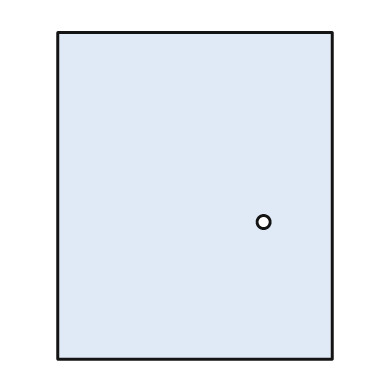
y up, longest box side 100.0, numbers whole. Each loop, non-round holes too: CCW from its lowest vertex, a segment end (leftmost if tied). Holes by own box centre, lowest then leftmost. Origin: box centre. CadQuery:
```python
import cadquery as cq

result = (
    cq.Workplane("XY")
    .moveTo(-42.0, -50.0)
    .lineTo(42.0, -50.0)
    .lineTo(42.0, 50.0)
    .lineTo(-42.0, 50.0)
    .close()
    .moveTo(21.0, -8.0)
    .circle(2.0)
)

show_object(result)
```